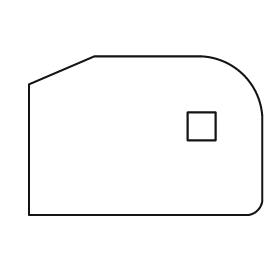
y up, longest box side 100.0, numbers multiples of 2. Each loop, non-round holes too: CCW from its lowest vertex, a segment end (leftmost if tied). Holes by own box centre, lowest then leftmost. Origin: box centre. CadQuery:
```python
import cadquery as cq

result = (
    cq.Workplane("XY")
    .moveTo(-50.0, -34.0)
    .lineTo(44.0, -34.0)
    .threePointArc((48.0, -32.0), (50.0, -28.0))
    .lineTo(50.0, 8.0)
    .threePointArc((42.0, 26.0), (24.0, 34.0))
    .lineTo(-22.0, 34.0)
    .lineTo(-50.0, 22.0)
    .close()
    .moveTo(18.0, -2.0)
    .lineTo(30.0, -2.0)
    .lineTo(30.0, 10.0)
    .lineTo(18.0, 10.0)
    .close()
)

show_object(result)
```